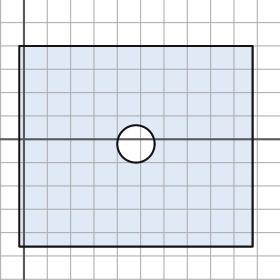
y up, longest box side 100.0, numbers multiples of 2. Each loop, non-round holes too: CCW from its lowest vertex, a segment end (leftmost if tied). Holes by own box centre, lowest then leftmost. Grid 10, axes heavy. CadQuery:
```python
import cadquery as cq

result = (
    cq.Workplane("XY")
    .moveTo(-2.0, -46.0)
    .lineTo(98.0, -46.0)
    .lineTo(98.0, 40.0)
    .lineTo(-2.0, 40.0)
    .close()
    .moveTo(48.0, -2.0)
    .circle(8.0)
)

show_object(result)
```